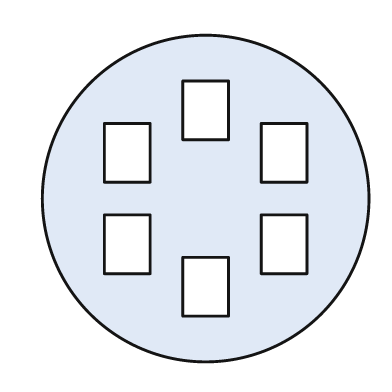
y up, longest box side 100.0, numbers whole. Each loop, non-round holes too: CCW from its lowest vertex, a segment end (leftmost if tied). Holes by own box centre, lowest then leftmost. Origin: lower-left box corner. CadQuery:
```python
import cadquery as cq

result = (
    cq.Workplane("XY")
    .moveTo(50.0, 50.0)
    .circle(50.0)
    .moveTo(43.0, 14.0)
    .lineTo(57.0, 14.0)
    .lineTo(57.0, 32.0)
    .lineTo(43.0, 32.0)
    .close()
    .moveTo(19.0, 27.0)
    .lineTo(33.0, 27.0)
    .lineTo(33.0, 45.0)
    .lineTo(19.0, 45.0)
    .close()
    .moveTo(67.0, 27.0)
    .lineTo(81.0, 27.0)
    .lineTo(81.0, 45.0)
    .lineTo(67.0, 45.0)
    .close()
    .moveTo(19.0, 55.0)
    .lineTo(33.0, 55.0)
    .lineTo(33.0, 73.0)
    .lineTo(19.0, 73.0)
    .close()
    .moveTo(67.0, 55.0)
    .lineTo(81.0, 55.0)
    .lineTo(81.0, 73.0)
    .lineTo(67.0, 73.0)
    .close()
    .moveTo(43.0, 68.0)
    .lineTo(57.0, 68.0)
    .lineTo(57.0, 86.0)
    .lineTo(43.0, 86.0)
    .close()
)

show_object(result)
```